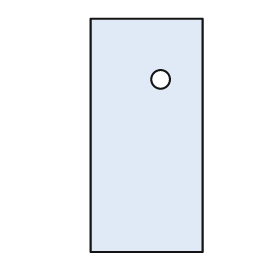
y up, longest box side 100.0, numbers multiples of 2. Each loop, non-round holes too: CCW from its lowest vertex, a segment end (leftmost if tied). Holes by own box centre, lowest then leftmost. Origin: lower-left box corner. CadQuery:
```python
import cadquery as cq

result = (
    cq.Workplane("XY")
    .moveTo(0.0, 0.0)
    .lineTo(48.0, 0.0)
    .lineTo(48.0, 100.0)
    .lineTo(0.0, 100.0)
    .close()
    .moveTo(30.0, 74.0)
    .circle(4.0)
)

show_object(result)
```